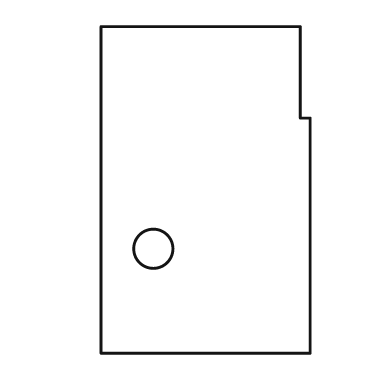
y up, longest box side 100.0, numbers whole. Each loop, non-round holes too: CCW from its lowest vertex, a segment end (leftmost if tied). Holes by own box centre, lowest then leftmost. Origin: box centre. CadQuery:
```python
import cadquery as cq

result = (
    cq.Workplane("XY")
    .moveTo(-32.0, -50.0)
    .lineTo(32.0, -50.0)
    .lineTo(32.0, 22.0)
    .lineTo(29.0, 22.0)
    .lineTo(29.0, 50.0)
    .lineTo(-32.0, 50.0)
    .close()
    .moveTo(-16.0, -18.0)
    .circle(6.0)
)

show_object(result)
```